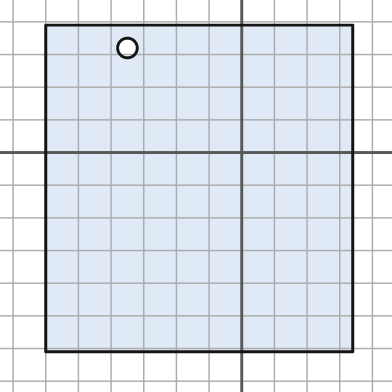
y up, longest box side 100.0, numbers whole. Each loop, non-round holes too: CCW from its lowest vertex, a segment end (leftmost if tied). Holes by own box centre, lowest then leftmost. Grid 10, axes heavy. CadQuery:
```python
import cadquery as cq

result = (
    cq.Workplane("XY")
    .moveTo(-60.0, -61.0)
    .lineTo(34.0, -61.0)
    .lineTo(34.0, 39.0)
    .lineTo(-60.0, 39.0)
    .close()
    .moveTo(-35.0, 32.0)
    .circle(3.0)
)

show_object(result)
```